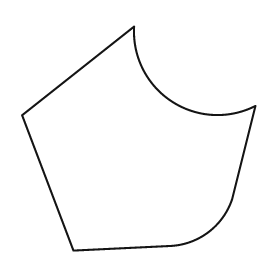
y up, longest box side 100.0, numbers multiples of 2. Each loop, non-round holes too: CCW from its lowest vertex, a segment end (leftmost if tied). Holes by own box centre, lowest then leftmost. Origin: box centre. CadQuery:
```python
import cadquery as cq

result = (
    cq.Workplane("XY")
    .moveTo(-28.0, -48.0)
    .lineTo(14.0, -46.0)
    .threePointArc((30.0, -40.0), (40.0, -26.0))
    .lineTo(50.0, 14.0)
    .threePointArc((14.0, 16.0), (-2.0, 48.0))
    .lineTo(-50.0, 10.0)
    .close()
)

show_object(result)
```